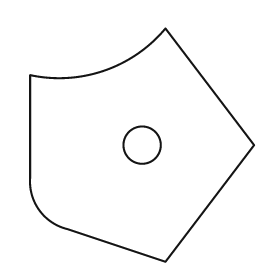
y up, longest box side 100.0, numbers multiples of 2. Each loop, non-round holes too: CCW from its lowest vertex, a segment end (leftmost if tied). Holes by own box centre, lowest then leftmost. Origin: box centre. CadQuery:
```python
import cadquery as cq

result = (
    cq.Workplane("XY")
    .moveTo(10.0, -50.0)
    .lineTo(48.0, 0.0)
    .lineTo(10.0, 50.0)
    .threePointArc((-16.0, 32.0), (-48.0, 30.0))
    .lineTo(-48.0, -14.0)
    .threePointArc((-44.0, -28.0), (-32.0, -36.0))
    .close()
    .moveTo(0.0, 0.0)
    .circle(8.0)
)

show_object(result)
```